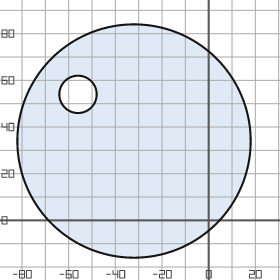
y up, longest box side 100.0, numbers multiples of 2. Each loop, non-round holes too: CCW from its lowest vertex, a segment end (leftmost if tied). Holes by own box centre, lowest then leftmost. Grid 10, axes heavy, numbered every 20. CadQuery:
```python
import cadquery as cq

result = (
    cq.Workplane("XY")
    .moveTo(-32.0, 34.0)
    .circle(50.0)
    .moveTo(-56.0, 54.0)
    .circle(8.0)
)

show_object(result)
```